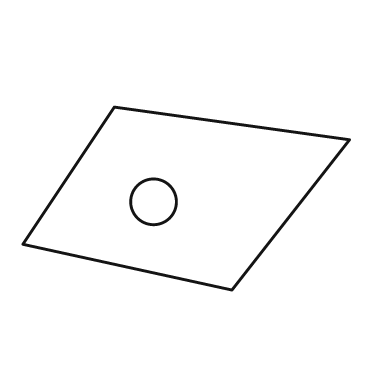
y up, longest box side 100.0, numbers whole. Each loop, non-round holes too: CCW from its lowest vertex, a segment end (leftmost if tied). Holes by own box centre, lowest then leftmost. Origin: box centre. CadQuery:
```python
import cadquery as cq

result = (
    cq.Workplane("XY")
    .moveTo(14.0, -28.0)
    .lineTo(50.0, 18.0)
    .lineTo(-22.0, 28.0)
    .lineTo(-50.0, -14.0)
    .close()
    .moveTo(-10.0, -1.0)
    .circle(7.0)
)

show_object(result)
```